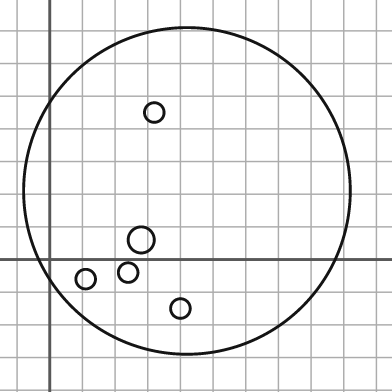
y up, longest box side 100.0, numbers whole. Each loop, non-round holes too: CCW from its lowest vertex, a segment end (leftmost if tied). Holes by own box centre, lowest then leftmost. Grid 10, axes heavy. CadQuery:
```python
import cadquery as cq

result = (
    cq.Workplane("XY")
    .moveTo(42.0, 21.0)
    .circle(50.0)
    .moveTo(40.0, -15.0)
    .circle(3.0)
    .moveTo(11.0, -6.0)
    .circle(3.0)
    .moveTo(24.0, -4.0)
    .circle(3.0)
    .moveTo(28.0, 6.0)
    .circle(4.0)
    .moveTo(32.0, 45.0)
    .circle(3.0)
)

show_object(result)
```